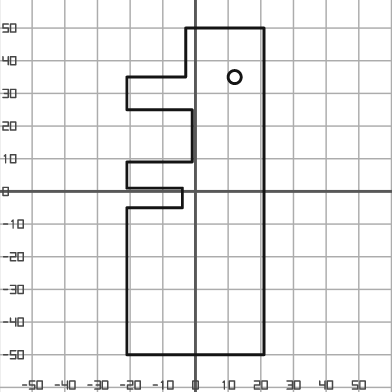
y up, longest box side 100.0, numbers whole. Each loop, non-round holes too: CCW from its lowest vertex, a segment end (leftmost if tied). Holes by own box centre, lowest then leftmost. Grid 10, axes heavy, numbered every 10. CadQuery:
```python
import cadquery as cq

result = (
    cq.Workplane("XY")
    .moveTo(-21.0, -50.0)
    .lineTo(21.0, -50.0)
    .lineTo(21.0, 50.0)
    .lineTo(-3.0, 50.0)
    .lineTo(-3.0, 35.0)
    .lineTo(-21.0, 35.0)
    .lineTo(-21.0, 25.0)
    .lineTo(-1.0, 25.0)
    .lineTo(-1.0, 9.0)
    .lineTo(-21.0, 9.0)
    .lineTo(-21.0, 1.0)
    .lineTo(-4.0, 1.0)
    .lineTo(-4.0, -5.0)
    .lineTo(-21.0, -5.0)
    .close()
    .moveTo(12.0, 35.0)
    .circle(2.0)
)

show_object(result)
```